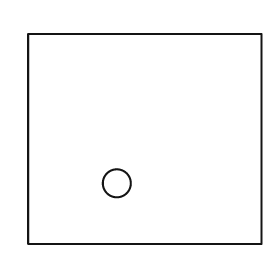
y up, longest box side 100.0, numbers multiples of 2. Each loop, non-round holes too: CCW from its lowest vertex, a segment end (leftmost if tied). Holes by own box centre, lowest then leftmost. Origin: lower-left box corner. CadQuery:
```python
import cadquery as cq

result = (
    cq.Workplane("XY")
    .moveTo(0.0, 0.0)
    .lineTo(100.0, 0.0)
    .lineTo(100.0, 90.0)
    .lineTo(0.0, 90.0)
    .close()
    .moveTo(38.0, 26.0)
    .circle(6.0)
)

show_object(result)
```